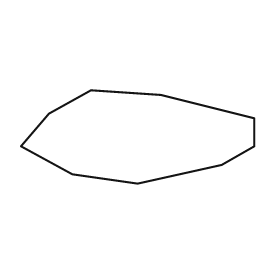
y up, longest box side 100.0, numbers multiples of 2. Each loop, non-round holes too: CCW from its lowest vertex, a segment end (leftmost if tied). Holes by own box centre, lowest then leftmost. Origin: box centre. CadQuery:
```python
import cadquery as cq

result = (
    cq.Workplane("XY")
    .moveTo(0.0, -20.0)
    .lineTo(36.0, -12.0)
    .lineTo(50.0, -4.0)
    .lineTo(50.0, 8.0)
    .lineTo(10.0, 18.0)
    .lineTo(-20.0, 20.0)
    .lineTo(-38.0, 10.0)
    .lineTo(-50.0, -4.0)
    .lineTo(-28.0, -16.0)
    .close()
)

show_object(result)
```